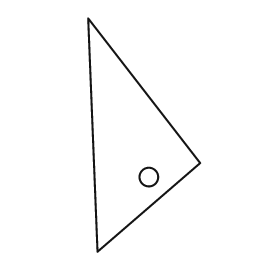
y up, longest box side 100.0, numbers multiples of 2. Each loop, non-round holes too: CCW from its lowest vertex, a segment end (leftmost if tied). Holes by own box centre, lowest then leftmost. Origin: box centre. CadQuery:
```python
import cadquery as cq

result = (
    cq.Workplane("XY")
    .moveTo(-20.0, -50.0)
    .lineTo(24.0, -12.0)
    .lineTo(-24.0, 50.0)
    .close()
    .moveTo(2.0, -18.0)
    .circle(4.0)
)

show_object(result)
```